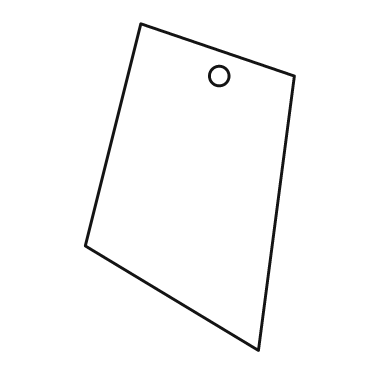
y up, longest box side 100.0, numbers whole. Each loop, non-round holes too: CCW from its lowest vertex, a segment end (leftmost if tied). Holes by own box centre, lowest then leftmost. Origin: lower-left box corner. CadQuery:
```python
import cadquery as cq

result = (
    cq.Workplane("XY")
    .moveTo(53.0, 0.0)
    .lineTo(64.0, 84.0)
    .lineTo(17.0, 100.0)
    .lineTo(0.0, 32.0)
    .close()
    .moveTo(41.0, 84.0)
    .circle(3.0)
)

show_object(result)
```